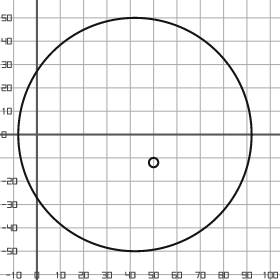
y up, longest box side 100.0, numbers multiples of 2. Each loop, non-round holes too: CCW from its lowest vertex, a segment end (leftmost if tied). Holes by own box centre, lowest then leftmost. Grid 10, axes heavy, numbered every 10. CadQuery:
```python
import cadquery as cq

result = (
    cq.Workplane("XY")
    .moveTo(42.0, 0.0)
    .circle(50.0)
    .moveTo(50.0, -12.0)
    .circle(2.0)
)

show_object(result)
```